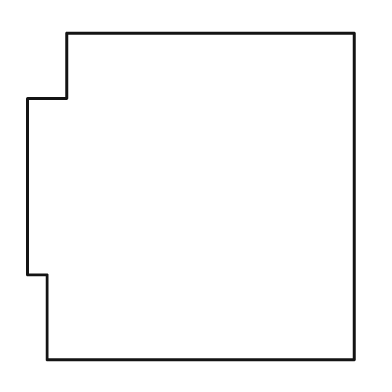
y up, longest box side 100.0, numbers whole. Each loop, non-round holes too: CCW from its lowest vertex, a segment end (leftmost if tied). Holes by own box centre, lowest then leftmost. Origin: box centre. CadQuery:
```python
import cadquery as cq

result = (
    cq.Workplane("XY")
    .moveTo(-44.0, -50.0)
    .lineTo(50.0, -50.0)
    .lineTo(50.0, 50.0)
    .lineTo(-38.0, 50.0)
    .lineTo(-38.0, 30.0)
    .lineTo(-50.0, 30.0)
    .lineTo(-50.0, -24.0)
    .lineTo(-44.0, -24.0)
    .close()
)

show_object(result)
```